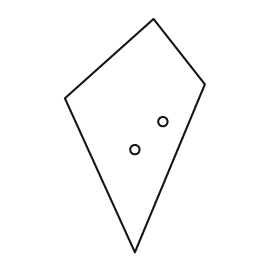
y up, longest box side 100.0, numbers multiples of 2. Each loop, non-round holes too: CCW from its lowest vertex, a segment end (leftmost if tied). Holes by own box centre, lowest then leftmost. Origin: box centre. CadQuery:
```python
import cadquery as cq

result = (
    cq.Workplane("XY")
    .moveTo(0.0, -50.0)
    .lineTo(30.0, 22.0)
    .lineTo(8.0, 50.0)
    .lineTo(-30.0, 16.0)
    .close()
    .moveTo(0.0, -6.0)
    .circle(2.0)
    .moveTo(12.0, 6.0)
    .circle(2.0)
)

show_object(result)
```